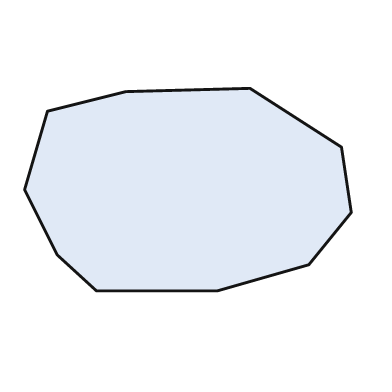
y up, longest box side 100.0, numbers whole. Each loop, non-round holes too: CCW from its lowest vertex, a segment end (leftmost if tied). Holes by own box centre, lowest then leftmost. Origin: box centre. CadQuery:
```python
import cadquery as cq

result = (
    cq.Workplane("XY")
    .moveTo(-28.0, -31.0)
    .lineTo(9.0, -31.0)
    .lineTo(37.0, -23.0)
    .lineTo(50.0, -7.0)
    .lineTo(47.0, 13.0)
    .lineTo(19.0, 31.0)
    .lineTo(-19.0, 30.0)
    .lineTo(-43.0, 24.0)
    .lineTo(-50.0, 0.0)
    .lineTo(-40.0, -20.0)
    .close()
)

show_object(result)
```